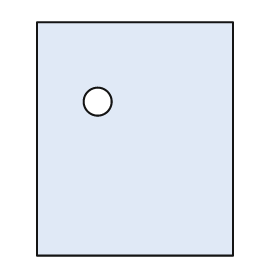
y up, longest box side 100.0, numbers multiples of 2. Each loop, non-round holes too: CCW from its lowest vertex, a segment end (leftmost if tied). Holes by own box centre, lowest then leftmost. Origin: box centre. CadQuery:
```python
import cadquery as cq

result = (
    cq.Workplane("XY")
    .moveTo(-42.0, -50.0)
    .lineTo(42.0, -50.0)
    .lineTo(42.0, 50.0)
    .lineTo(-42.0, 50.0)
    .close()
    .moveTo(-16.0, 16.0)
    .circle(6.0)
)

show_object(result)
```